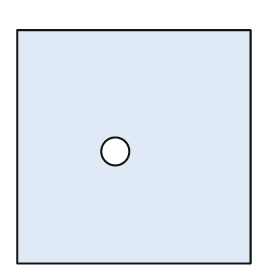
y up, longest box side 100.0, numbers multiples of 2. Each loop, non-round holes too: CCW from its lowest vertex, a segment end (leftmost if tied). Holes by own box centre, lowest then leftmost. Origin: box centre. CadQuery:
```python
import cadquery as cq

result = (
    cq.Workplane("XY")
    .moveTo(-50.0, -50.0)
    .lineTo(50.0, -50.0)
    .lineTo(50.0, 50.0)
    .lineTo(-50.0, 50.0)
    .close()
    .moveTo(-8.0, -2.0)
    .circle(6.0)
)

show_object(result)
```